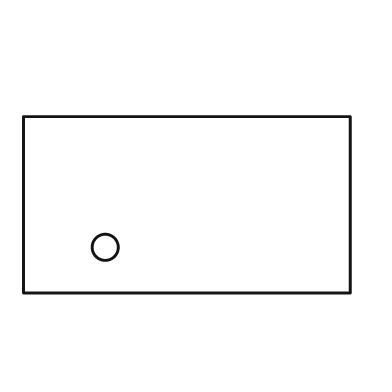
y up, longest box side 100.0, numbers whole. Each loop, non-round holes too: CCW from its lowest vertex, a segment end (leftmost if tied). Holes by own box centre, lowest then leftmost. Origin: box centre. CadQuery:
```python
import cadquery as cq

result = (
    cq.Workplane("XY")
    .moveTo(-50.0, -27.0)
    .lineTo(50.0, -27.0)
    .lineTo(50.0, 27.0)
    .lineTo(-50.0, 27.0)
    .close()
    .moveTo(-25.0, -13.0)
    .circle(4.0)
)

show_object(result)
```